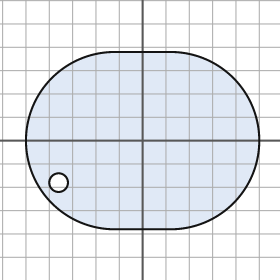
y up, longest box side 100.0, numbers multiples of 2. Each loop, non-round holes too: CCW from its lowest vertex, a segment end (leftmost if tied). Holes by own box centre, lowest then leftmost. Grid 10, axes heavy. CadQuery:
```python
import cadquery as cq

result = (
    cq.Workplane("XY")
    .moveTo(-12.0, -38.0)
    .lineTo(12.0, -38.0)
    .threePointArc((50.0, 0.0), (12.0, 38.0))
    .lineTo(-12.0, 38.0)
    .threePointArc((-50.0, 0.0), (-12.0, -38.0))
    .close()
    .moveTo(-36.0, -18.0)
    .circle(4.0)
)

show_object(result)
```